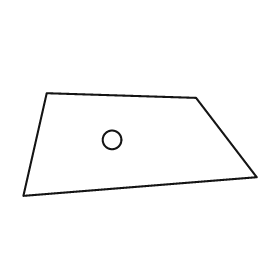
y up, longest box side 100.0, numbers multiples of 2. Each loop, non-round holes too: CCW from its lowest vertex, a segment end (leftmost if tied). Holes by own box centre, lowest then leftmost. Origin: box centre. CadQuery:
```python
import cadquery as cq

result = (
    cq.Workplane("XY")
    .moveTo(-50.0, -22.0)
    .lineTo(50.0, -14.0)
    .lineTo(24.0, 20.0)
    .lineTo(-40.0, 22.0)
    .close()
    .moveTo(-12.0, 2.0)
    .circle(4.0)
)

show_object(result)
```